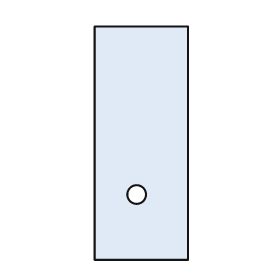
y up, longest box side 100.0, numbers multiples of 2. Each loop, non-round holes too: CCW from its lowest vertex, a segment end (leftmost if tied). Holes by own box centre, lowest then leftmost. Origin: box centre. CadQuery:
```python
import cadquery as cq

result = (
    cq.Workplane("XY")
    .moveTo(-20.0, -50.0)
    .lineTo(20.0, -50.0)
    .lineTo(20.0, 50.0)
    .lineTo(-20.0, 50.0)
    .close()
    .moveTo(-2.0, -22.0)
    .circle(4.0)
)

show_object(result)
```